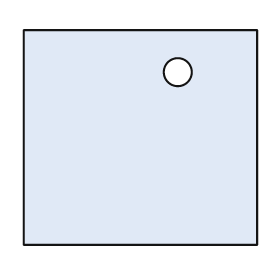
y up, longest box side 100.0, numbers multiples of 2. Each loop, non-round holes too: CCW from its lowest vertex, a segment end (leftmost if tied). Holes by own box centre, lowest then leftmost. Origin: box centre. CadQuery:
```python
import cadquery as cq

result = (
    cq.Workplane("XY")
    .moveTo(-50.0, -46.0)
    .lineTo(50.0, -46.0)
    .lineTo(50.0, 46.0)
    .lineTo(-50.0, 46.0)
    .close()
    .moveTo(16.0, 28.0)
    .circle(6.0)
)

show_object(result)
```